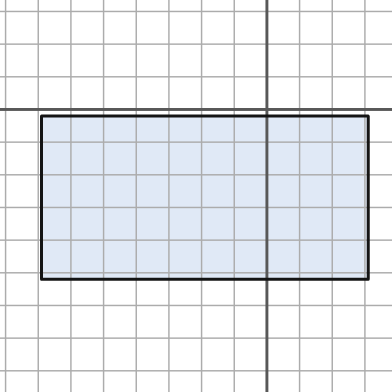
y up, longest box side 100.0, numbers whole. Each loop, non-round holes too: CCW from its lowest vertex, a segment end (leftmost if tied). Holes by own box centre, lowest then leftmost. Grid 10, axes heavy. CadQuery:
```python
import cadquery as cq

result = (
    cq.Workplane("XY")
    .moveTo(-69.0, -52.0)
    .lineTo(31.0, -52.0)
    .lineTo(31.0, -2.0)
    .lineTo(-69.0, -2.0)
    .close()
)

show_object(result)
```